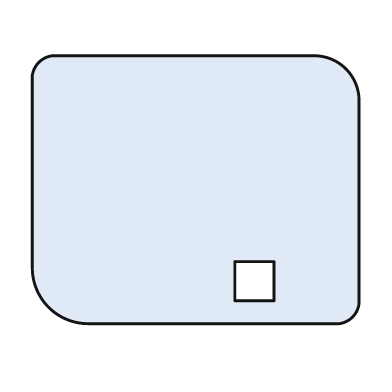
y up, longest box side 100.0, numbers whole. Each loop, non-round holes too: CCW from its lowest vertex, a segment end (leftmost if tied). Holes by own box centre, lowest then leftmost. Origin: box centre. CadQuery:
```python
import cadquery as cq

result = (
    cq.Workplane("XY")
    .moveTo(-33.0, -41.0)
    .lineTo(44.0, -41.0)
    .threePointArc((48.0, -39.0), (50.0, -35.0))
    .lineTo(50.0, 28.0)
    .threePointArc((46.0, 37.0), (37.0, 41.0))
    .lineTo(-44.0, 41.0)
    .threePointArc((-48.0, 39.0), (-50.0, 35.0))
    .lineTo(-50.0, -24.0)
    .threePointArc((-45.0, -36.0), (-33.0, -41.0))
    .close()
    .moveTo(12.0, -34.0)
    .lineTo(24.0, -34.0)
    .lineTo(24.0, -22.0)
    .lineTo(12.0, -22.0)
    .close()
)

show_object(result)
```